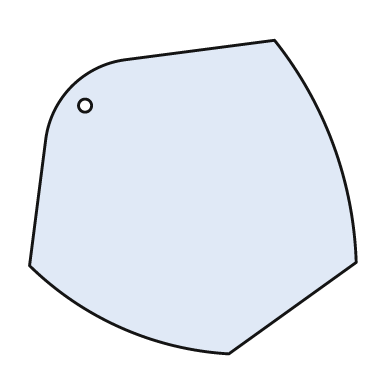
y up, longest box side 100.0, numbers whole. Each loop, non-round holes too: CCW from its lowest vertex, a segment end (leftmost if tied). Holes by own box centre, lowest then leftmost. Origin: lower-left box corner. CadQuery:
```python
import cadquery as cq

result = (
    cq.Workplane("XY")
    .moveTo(61.0, 0.0)
    .lineTo(100.0, 28.0)
    .threePointArc((93.0, 64.0), (75.0, 96.0))
    .lineTo(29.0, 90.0)
    .threePointArc((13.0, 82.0), (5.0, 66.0))
    .lineTo(0.0, 27.0)
    .threePointArc((28.0, 8.0), (61.0, 0.0))
    .close()
    .moveTo(17.0, 76.0)
    .circle(2.0)
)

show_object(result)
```